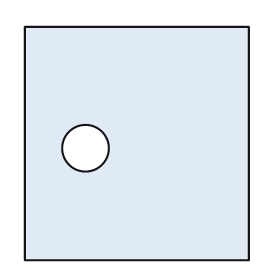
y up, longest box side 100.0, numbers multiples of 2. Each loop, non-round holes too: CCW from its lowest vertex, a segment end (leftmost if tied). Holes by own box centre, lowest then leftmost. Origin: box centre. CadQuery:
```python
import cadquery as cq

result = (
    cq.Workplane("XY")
    .moveTo(-48.0, -50.0)
    .lineTo(48.0, -50.0)
    .lineTo(48.0, 50.0)
    .lineTo(-48.0, 50.0)
    .close()
    .moveTo(-22.0, -2.0)
    .circle(10.0)
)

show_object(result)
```